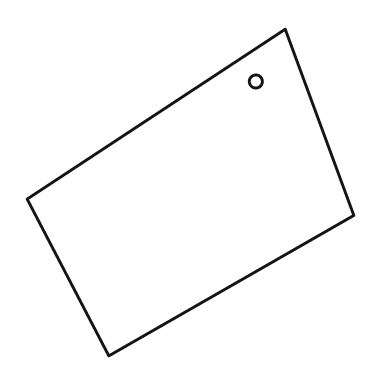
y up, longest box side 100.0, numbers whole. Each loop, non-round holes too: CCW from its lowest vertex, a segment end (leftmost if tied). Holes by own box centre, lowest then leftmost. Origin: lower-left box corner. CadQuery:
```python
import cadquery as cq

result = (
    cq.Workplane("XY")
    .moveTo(25.0, 0.0)
    .lineTo(100.0, 43.0)
    .lineTo(79.0, 100.0)
    .lineTo(0.0, 48.0)
    .close()
    .moveTo(70.0, 84.0)
    .circle(2.0)
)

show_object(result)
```